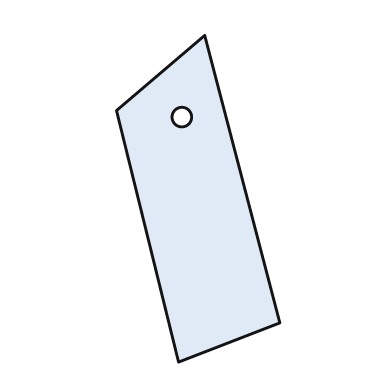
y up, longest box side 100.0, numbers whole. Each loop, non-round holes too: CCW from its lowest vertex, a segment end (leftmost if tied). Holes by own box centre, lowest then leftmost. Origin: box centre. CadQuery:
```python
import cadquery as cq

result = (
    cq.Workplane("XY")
    .moveTo(-6.0, -50.0)
    .lineTo(25.0, -38.0)
    .lineTo(2.0, 50.0)
    .lineTo(-25.0, 27.0)
    .close()
    .moveTo(-5.0, 25.0)
    .circle(3.0)
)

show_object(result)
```